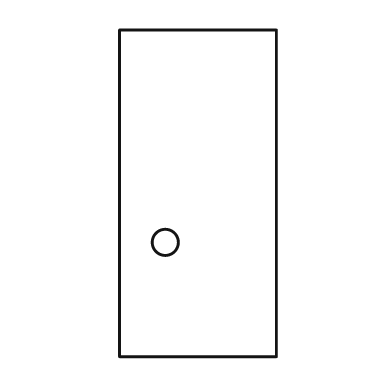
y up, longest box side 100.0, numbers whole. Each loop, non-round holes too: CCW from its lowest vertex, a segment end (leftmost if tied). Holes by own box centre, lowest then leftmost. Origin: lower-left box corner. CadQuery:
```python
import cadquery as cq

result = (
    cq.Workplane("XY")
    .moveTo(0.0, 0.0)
    .lineTo(48.0, 0.0)
    .lineTo(48.0, 100.0)
    .lineTo(0.0, 100.0)
    .close()
    .moveTo(14.0, 35.0)
    .circle(4.0)
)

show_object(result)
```